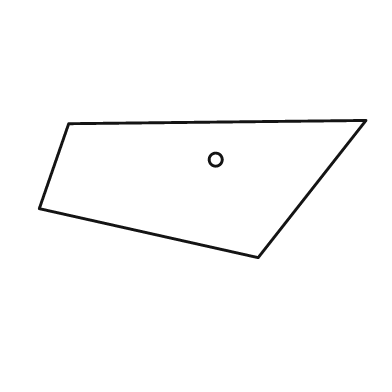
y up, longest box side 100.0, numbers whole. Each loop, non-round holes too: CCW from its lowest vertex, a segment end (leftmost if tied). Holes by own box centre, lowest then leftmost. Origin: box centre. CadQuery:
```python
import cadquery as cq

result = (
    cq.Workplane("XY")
    .moveTo(17.0, -21.0)
    .lineTo(50.0, 21.0)
    .lineTo(-41.0, 20.0)
    .lineTo(-50.0, -6.0)
    .close()
    .moveTo(4.0, 9.0)
    .circle(2.0)
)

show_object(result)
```